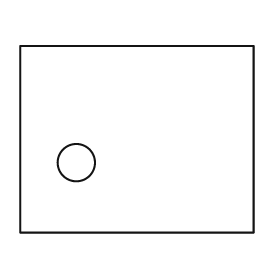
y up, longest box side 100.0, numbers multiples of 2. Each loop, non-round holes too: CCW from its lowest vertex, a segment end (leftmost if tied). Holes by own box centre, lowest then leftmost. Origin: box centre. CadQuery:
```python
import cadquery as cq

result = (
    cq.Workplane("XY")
    .moveTo(-50.0, -40.0)
    .lineTo(50.0, -40.0)
    .lineTo(50.0, 40.0)
    .lineTo(-50.0, 40.0)
    .close()
    .moveTo(-26.0, -10.0)
    .circle(8.0)
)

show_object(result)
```